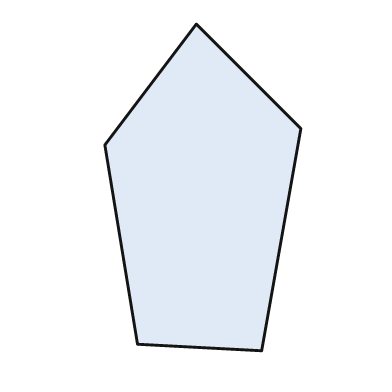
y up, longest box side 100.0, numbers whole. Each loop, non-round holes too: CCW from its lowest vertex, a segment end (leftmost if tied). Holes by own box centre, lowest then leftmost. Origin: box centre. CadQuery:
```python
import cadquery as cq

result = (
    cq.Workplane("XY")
    .moveTo(18.0, -50.0)
    .lineTo(30.0, 18.0)
    .lineTo(-2.0, 50.0)
    .lineTo(-30.0, 13.0)
    .lineTo(-20.0, -48.0)
    .close()
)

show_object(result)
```